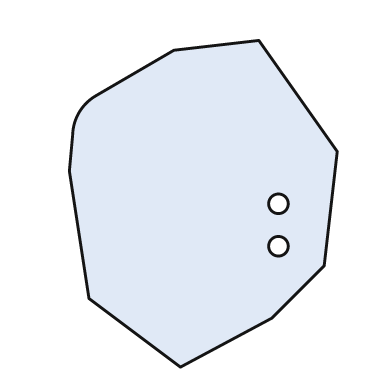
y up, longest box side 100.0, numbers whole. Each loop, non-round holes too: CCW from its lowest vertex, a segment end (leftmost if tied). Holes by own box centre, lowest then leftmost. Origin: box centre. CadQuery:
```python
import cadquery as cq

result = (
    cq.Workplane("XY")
    .moveTo(-7.0, -50.0)
    .lineTo(21.0, -35.0)
    .lineTo(37.0, -19.0)
    .lineTo(41.0, 16.0)
    .lineTo(17.0, 50.0)
    .lineTo(-9.0, 47.0)
    .lineTo(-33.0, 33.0)
    .threePointArc((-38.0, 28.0), (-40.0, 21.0))
    .lineTo(-41.0, 10.0)
    .lineTo(-35.0, -29.0)
    .close()
    .moveTo(23.0, -13.0)
    .circle(3.0)
    .moveTo(23.0, 0.0)
    .circle(3.0)
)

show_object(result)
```